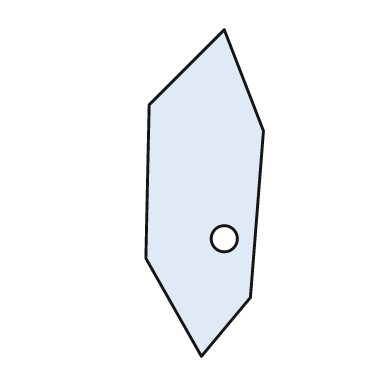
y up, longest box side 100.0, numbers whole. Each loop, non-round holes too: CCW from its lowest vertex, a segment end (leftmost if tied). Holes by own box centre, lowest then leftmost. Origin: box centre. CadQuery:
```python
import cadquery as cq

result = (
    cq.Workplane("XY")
    .moveTo(-1.0, -50.0)
    .lineTo(14.0, -32.0)
    .lineTo(18.0, 19.0)
    .lineTo(6.0, 50.0)
    .lineTo(-17.0, 27.0)
    .lineTo(-18.0, -20.0)
    .close()
    .moveTo(6.0, -14.0)
    .circle(4.0)
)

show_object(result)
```